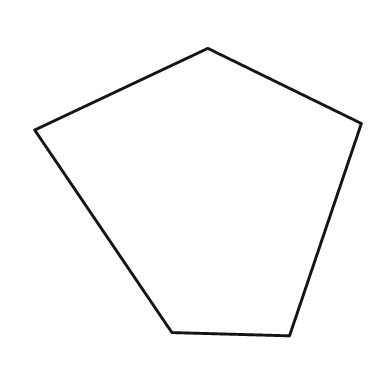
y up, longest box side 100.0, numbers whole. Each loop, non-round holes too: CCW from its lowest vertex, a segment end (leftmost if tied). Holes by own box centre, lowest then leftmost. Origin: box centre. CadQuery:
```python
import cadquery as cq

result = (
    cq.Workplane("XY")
    .moveTo(28.0, -44.0)
    .lineTo(50.0, 21.0)
    .lineTo(3.0, 44.0)
    .lineTo(-50.0, 19.0)
    .lineTo(-8.0, -43.0)
    .close()
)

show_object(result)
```